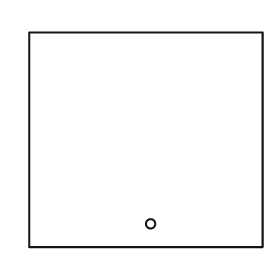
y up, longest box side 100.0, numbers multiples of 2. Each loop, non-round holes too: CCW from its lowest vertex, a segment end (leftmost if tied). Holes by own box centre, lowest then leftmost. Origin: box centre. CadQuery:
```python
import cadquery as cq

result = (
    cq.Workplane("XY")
    .moveTo(-50.0, -46.0)
    .lineTo(50.0, -46.0)
    .lineTo(50.0, 46.0)
    .lineTo(-50.0, 46.0)
    .close()
    .moveTo(2.0, -36.0)
    .circle(2.0)
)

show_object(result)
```